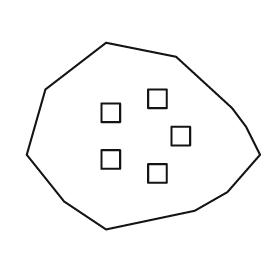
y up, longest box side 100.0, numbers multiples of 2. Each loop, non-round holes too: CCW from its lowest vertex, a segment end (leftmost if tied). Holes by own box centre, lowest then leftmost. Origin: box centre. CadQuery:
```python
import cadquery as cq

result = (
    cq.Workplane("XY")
    .moveTo(-16.0, -40.0)
    .lineTo(22.0, -32.0)
    .lineTo(36.0, -24.0)
    .lineTo(50.0, -8.0)
    .lineTo(44.0, 4.0)
    .lineTo(38.0, 12.0)
    .lineTo(14.0, 34.0)
    .lineTo(-16.0, 40.0)
    .lineTo(-42.0, 20.0)
    .lineTo(-50.0, -8.0)
    .lineTo(-34.0, -28.0)
    .close()
    .moveTo(2.0, -20.0)
    .lineTo(10.0, -20.0)
    .lineTo(10.0, -12.0)
    .lineTo(2.0, -12.0)
    .close()
    .moveTo(-18.0, -14.0)
    .lineTo(-10.0, -14.0)
    .lineTo(-10.0, -6.0)
    .lineTo(-18.0, -6.0)
    .close()
    .moveTo(12.0, -4.0)
    .lineTo(20.0, -4.0)
    .lineTo(20.0, 4.0)
    .lineTo(12.0, 4.0)
    .close()
    .moveTo(-18.0, 6.0)
    .lineTo(-10.0, 6.0)
    .lineTo(-10.0, 14.0)
    .lineTo(-18.0, 14.0)
    .close()
    .moveTo(2.0, 12.0)
    .lineTo(10.0, 12.0)
    .lineTo(10.0, 20.0)
    .lineTo(2.0, 20.0)
    .close()
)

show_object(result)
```